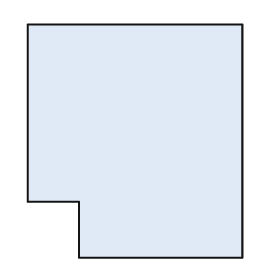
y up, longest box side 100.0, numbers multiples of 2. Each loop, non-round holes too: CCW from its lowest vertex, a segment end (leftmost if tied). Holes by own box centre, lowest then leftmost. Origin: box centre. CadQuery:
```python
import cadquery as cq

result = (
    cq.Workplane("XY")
    .moveTo(-24.0, -50.0)
    .lineTo(46.0, -50.0)
    .lineTo(46.0, 50.0)
    .lineTo(-46.0, 50.0)
    .lineTo(-46.0, -26.0)
    .lineTo(-24.0, -26.0)
    .close()
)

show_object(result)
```